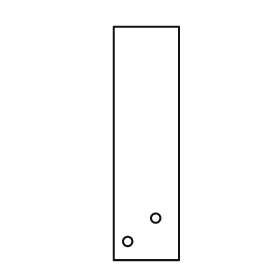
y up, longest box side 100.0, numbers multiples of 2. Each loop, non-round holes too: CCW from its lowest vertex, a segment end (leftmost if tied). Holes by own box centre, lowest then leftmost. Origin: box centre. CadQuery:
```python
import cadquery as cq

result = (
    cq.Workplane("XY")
    .moveTo(-14.0, -50.0)
    .lineTo(14.0, -50.0)
    .lineTo(14.0, 50.0)
    .lineTo(-14.0, 50.0)
    .close()
    .moveTo(-8.0, -42.0)
    .circle(2.0)
    .moveTo(4.0, -32.0)
    .circle(2.0)
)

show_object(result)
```